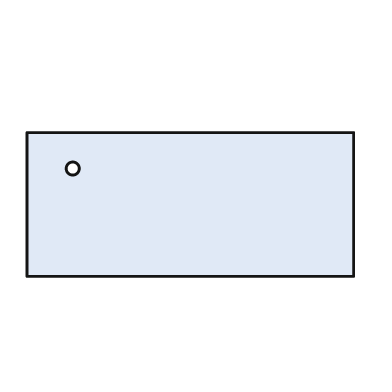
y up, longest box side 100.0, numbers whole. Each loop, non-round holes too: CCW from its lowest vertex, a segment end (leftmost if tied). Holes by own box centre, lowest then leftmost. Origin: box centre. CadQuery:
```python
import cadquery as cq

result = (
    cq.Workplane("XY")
    .moveTo(-50.0, -22.0)
    .lineTo(50.0, -22.0)
    .lineTo(50.0, 22.0)
    .lineTo(-50.0, 22.0)
    .close()
    .moveTo(-36.0, 11.0)
    .circle(2.0)
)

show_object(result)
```